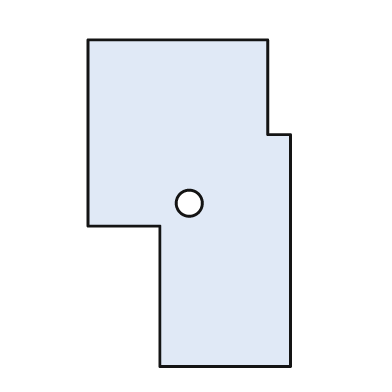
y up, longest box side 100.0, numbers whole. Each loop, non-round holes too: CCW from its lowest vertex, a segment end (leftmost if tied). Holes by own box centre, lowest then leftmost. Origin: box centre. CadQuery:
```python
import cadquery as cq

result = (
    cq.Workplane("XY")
    .moveTo(-9.0, -50.0)
    .lineTo(31.0, -50.0)
    .lineTo(31.0, 21.0)
    .lineTo(24.0, 21.0)
    .lineTo(24.0, 50.0)
    .lineTo(-31.0, 50.0)
    .lineTo(-31.0, -7.0)
    .lineTo(-9.0, -7.0)
    .close()
    .moveTo(0.0, 0.0)
    .circle(4.0)
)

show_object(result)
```